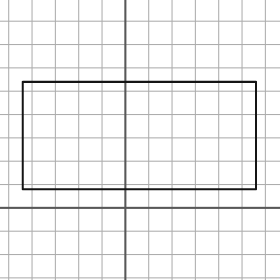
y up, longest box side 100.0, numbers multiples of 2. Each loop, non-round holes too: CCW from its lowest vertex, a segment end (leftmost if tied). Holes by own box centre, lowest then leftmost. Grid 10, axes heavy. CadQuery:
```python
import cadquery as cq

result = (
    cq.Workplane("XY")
    .moveTo(-44.0, 8.0)
    .lineTo(56.0, 8.0)
    .lineTo(56.0, 54.0)
    .lineTo(-44.0, 54.0)
    .close()
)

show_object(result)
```